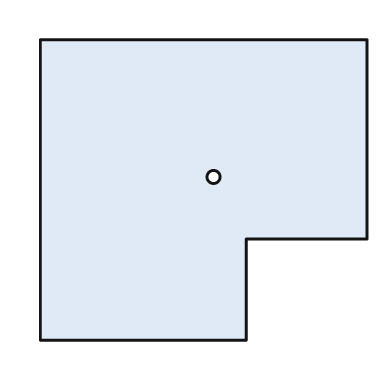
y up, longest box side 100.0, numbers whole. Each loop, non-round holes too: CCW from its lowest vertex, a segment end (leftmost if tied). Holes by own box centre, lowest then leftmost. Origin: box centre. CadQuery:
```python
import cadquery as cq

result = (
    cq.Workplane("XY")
    .moveTo(-50.0, -46.0)
    .lineTo(13.0, -46.0)
    .lineTo(13.0, -15.0)
    .lineTo(50.0, -15.0)
    .lineTo(50.0, 46.0)
    .lineTo(-50.0, 46.0)
    .close()
    .moveTo(3.0, 4.0)
    .circle(2.0)
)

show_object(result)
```